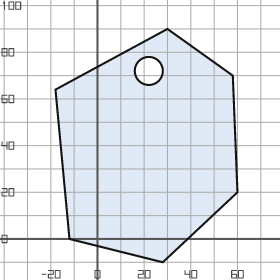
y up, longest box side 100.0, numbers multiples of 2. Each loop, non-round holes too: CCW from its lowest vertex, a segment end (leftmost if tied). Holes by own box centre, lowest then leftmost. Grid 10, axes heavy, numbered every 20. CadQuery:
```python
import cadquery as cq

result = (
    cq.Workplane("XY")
    .moveTo(28.0, -10.0)
    .lineTo(60.0, 20.0)
    .lineTo(58.0, 70.0)
    .lineTo(30.0, 90.0)
    .lineTo(-18.0, 64.0)
    .lineTo(-12.0, 0.0)
    .close()
    .moveTo(22.0, 72.0)
    .circle(6.0)
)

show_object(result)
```